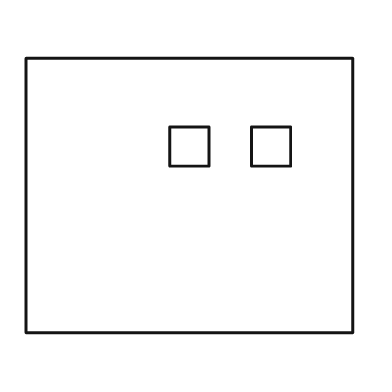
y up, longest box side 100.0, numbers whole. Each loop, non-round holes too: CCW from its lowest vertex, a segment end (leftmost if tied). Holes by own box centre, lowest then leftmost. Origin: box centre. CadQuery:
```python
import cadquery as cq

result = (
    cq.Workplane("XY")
    .moveTo(-50.0, -42.0)
    .lineTo(50.0, -42.0)
    .lineTo(50.0, 42.0)
    .lineTo(-50.0, 42.0)
    .close()
    .moveTo(-6.0, 9.0)
    .lineTo(6.0, 9.0)
    .lineTo(6.0, 21.0)
    .lineTo(-6.0, 21.0)
    .close()
    .moveTo(19.0, 9.0)
    .lineTo(31.0, 9.0)
    .lineTo(31.0, 21.0)
    .lineTo(19.0, 21.0)
    .close()
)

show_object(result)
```